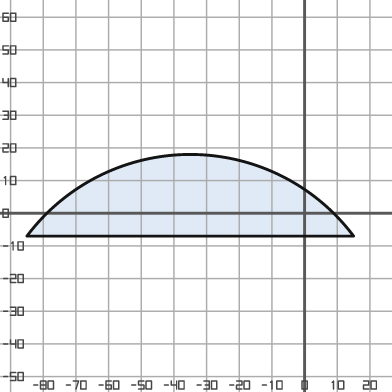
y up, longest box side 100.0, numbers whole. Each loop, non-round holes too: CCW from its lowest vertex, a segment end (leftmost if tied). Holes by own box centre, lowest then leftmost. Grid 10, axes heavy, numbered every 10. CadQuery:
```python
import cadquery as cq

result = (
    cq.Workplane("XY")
    .moveTo(-85.0, -7.0)
    .lineTo(15.0, -7.0)
    .threePointArc((-35.0, 18.0), (-85.0, -7.0))
    .close()
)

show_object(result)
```